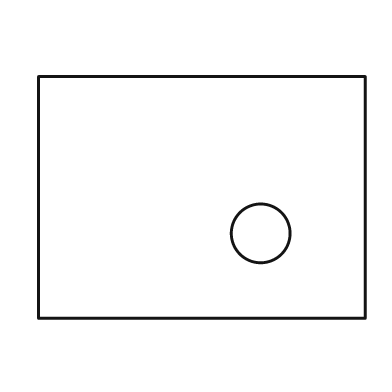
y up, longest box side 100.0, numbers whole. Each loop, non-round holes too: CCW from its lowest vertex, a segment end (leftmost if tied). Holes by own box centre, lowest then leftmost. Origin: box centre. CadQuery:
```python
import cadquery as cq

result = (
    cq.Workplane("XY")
    .moveTo(-50.0, -37.0)
    .lineTo(50.0, -37.0)
    .lineTo(50.0, 37.0)
    .lineTo(-50.0, 37.0)
    .close()
    .moveTo(18.0, -11.0)
    .circle(9.0)
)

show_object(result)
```